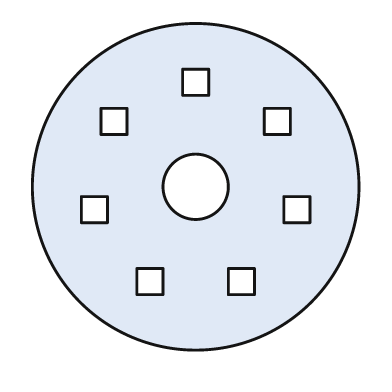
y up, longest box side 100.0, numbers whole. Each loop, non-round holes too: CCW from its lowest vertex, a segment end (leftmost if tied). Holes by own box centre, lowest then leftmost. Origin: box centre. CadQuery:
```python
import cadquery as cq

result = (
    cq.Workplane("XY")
    .moveTo(0.0, 0.0)
    .circle(50.0)
    .moveTo(-18.0, -33.0)
    .lineTo(-10.0, -33.0)
    .lineTo(-10.0, -25.0)
    .lineTo(-18.0, -25.0)
    .close()
    .moveTo(10.0, -33.0)
    .lineTo(18.0, -33.0)
    .lineTo(18.0, -25.0)
    .lineTo(10.0, -25.0)
    .close()
    .moveTo(-35.0, -11.0)
    .lineTo(-27.0, -11.0)
    .lineTo(-27.0, -3.0)
    .lineTo(-35.0, -3.0)
    .close()
    .moveTo(27.0, -11.0)
    .lineTo(35.0, -11.0)
    .lineTo(35.0, -3.0)
    .lineTo(27.0, -3.0)
    .close()
    .moveTo(0.0, 0.0)
    .circle(10.0)
    .moveTo(-29.0, 16.0)
    .lineTo(-21.0, 16.0)
    .lineTo(-21.0, 24.0)
    .lineTo(-29.0, 24.0)
    .close()
    .moveTo(21.0, 16.0)
    .lineTo(29.0, 16.0)
    .lineTo(29.0, 24.0)
    .lineTo(21.0, 24.0)
    .close()
    .moveTo(-4.0, 28.0)
    .lineTo(4.0, 28.0)
    .lineTo(4.0, 36.0)
    .lineTo(-4.0, 36.0)
    .close()
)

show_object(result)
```